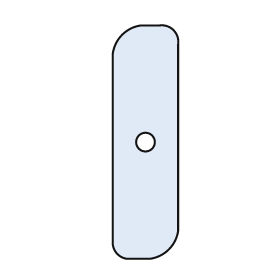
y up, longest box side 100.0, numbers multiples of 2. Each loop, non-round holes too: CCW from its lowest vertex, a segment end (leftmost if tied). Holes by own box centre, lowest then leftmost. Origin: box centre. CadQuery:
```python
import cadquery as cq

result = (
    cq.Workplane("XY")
    .moveTo(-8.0, -50.0)
    .lineTo(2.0, -50.0)
    .threePointArc((10.0, -46.0), (14.0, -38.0))
    .lineTo(14.0, 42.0)
    .threePointArc((12.0, 48.0), (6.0, 50.0))
    .lineTo(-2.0, 50.0)
    .threePointArc((-10.0, 46.0), (-14.0, 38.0))
    .lineTo(-14.0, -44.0)
    .threePointArc((-12.0, -48.0), (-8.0, -50.0))
    .close()
    .moveTo(0.0, 0.0)
    .circle(4.0)
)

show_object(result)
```